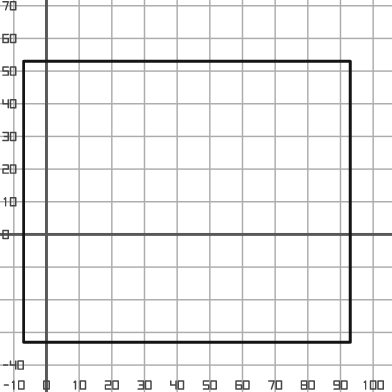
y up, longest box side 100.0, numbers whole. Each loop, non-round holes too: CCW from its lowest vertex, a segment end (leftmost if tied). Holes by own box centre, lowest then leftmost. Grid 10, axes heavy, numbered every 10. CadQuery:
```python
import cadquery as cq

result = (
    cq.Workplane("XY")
    .moveTo(-7.0, -33.0)
    .lineTo(93.0, -33.0)
    .lineTo(93.0, 53.0)
    .lineTo(-7.0, 53.0)
    .close()
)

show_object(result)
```